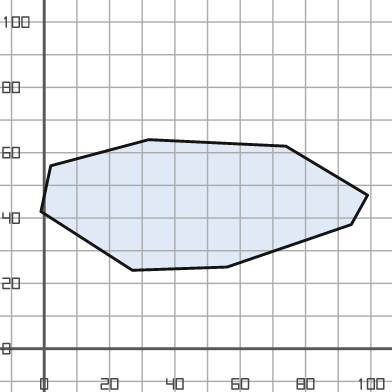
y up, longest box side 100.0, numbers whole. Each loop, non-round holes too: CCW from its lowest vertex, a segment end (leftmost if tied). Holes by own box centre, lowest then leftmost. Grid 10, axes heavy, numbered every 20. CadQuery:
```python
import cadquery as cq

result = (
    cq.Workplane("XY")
    .moveTo(27.0, 24.0)
    .lineTo(56.0, 25.0)
    .lineTo(94.0, 38.0)
    .lineTo(99.0, 47.0)
    .lineTo(74.0, 62.0)
    .lineTo(32.0, 64.0)
    .lineTo(2.0, 56.0)
    .lineTo(-1.0, 42.0)
    .close()
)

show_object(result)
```